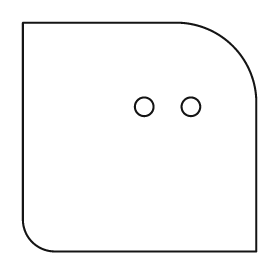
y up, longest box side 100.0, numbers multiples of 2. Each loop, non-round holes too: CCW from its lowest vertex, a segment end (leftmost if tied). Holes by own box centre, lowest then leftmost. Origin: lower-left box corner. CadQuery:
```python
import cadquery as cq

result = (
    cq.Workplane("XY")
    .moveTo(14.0, 0.0)
    .lineTo(100.0, 0.0)
    .lineTo(100.0, 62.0)
    .threePointArc((90.0, 88.0), (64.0, 98.0))
    .lineTo(0.0, 98.0)
    .lineTo(0.0, 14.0)
    .threePointArc((4.0, 4.0), (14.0, 0.0))
    .close()
    .moveTo(52.0, 62.0)
    .circle(4.0)
    .moveTo(72.0, 62.0)
    .circle(4.0)
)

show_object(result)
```